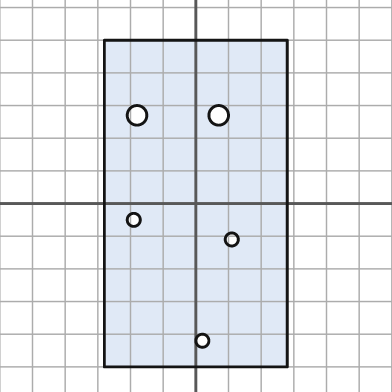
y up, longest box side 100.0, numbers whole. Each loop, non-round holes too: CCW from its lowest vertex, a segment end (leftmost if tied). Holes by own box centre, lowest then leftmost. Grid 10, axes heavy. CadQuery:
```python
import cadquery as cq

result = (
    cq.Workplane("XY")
    .moveTo(-28.0, -50.0)
    .lineTo(28.0, -50.0)
    .lineTo(28.0, 50.0)
    .lineTo(-28.0, 50.0)
    .close()
    .moveTo(2.0, -42.0)
    .circle(2.0)
    .moveTo(11.0, -11.0)
    .circle(2.0)
    .moveTo(-19.0, -5.0)
    .circle(2.0)
    .moveTo(-18.0, 27.0)
    .circle(3.0)
    .moveTo(7.0, 27.0)
    .circle(3.0)
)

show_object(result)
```